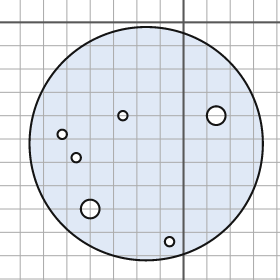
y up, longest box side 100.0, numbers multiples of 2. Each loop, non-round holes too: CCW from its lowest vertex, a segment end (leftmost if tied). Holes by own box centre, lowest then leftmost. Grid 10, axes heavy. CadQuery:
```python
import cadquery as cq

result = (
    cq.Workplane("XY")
    .moveTo(-16.0, -52.0)
    .circle(50.0)
    .moveTo(-6.0, -94.0)
    .circle(2.0)
    .moveTo(-40.0, -80.0)
    .circle(4.0)
    .moveTo(-46.0, -58.0)
    .circle(2.0)
    .moveTo(-52.0, -48.0)
    .circle(2.0)
    .moveTo(-26.0, -40.0)
    .circle(2.0)
    .moveTo(14.0, -40.0)
    .circle(4.0)
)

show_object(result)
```